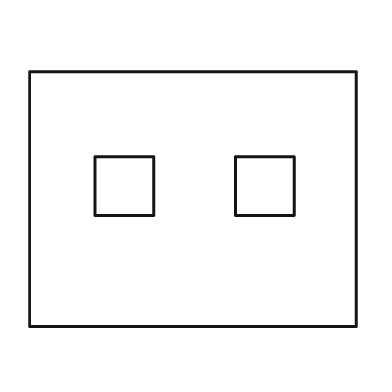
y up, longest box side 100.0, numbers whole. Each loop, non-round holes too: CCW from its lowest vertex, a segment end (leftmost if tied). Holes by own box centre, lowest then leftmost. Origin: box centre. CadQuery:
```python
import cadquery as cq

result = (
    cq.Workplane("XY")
    .moveTo(-50.0, -39.0)
    .lineTo(50.0, -39.0)
    .lineTo(50.0, 39.0)
    .lineTo(-50.0, 39.0)
    .close()
    .moveTo(-30.0, -5.0)
    .lineTo(-12.0, -5.0)
    .lineTo(-12.0, 13.0)
    .lineTo(-30.0, 13.0)
    .close()
    .moveTo(13.0, -5.0)
    .lineTo(31.0, -5.0)
    .lineTo(31.0, 13.0)
    .lineTo(13.0, 13.0)
    .close()
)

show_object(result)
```